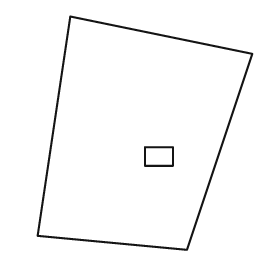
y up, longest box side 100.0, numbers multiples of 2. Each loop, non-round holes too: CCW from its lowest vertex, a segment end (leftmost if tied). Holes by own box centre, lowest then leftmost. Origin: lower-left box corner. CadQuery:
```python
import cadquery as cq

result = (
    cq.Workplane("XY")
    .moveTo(64.0, 0.0)
    .lineTo(92.0, 84.0)
    .lineTo(14.0, 100.0)
    .lineTo(0.0, 6.0)
    .close()
    .moveTo(46.0, 36.0)
    .lineTo(58.0, 36.0)
    .lineTo(58.0, 44.0)
    .lineTo(46.0, 44.0)
    .close()
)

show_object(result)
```